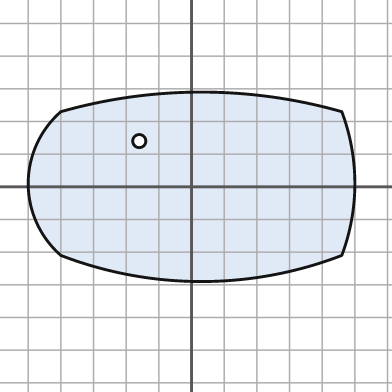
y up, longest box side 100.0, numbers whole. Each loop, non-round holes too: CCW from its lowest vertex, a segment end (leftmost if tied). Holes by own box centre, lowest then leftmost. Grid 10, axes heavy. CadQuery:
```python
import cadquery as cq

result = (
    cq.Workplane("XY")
    .moveTo(-40.0, -21.0)
    .threePointArc((3.0, -29.0), (46.0, -21.0))
    .threePointArc((50.0, 1.0), (46.0, 23.0))
    .threePointArc((3.0, 29.0), (-40.0, 23.0))
    .threePointArc((-50.0, 1.0), (-40.0, -21.0))
    .close()
    .moveTo(-16.0, 14.0)
    .circle(2.0)
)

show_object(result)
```